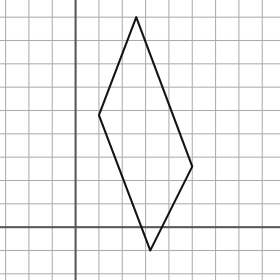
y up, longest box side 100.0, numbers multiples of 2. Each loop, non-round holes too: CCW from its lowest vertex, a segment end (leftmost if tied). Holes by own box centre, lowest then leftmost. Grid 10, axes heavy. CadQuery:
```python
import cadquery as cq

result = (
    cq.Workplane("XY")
    .moveTo(32.0, -10.0)
    .lineTo(50.0, 26.0)
    .lineTo(26.0, 90.0)
    .lineTo(10.0, 48.0)
    .close()
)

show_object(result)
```